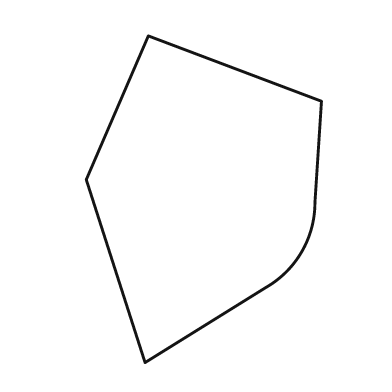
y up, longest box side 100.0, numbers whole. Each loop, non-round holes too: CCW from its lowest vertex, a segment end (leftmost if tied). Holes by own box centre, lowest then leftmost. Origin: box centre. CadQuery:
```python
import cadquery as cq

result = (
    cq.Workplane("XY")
    .moveTo(-18.0, -50.0)
    .lineTo(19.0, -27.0)
    .threePointArc((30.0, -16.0), (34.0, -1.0))
    .lineTo(36.0, 30.0)
    .lineTo(-17.0, 50.0)
    .lineTo(-36.0, 6.0)
    .close()
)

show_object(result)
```